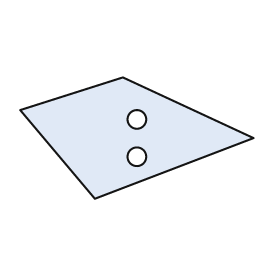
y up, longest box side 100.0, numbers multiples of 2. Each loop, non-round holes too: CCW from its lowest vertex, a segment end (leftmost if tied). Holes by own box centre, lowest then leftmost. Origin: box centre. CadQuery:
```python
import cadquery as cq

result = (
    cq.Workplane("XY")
    .moveTo(-18.0, -26.0)
    .lineTo(50.0, 0.0)
    .lineTo(-6.0, 26.0)
    .lineTo(-50.0, 12.0)
    .close()
    .moveTo(0.0, -8.0)
    .circle(4.0)
    .moveTo(0.0, 8.0)
    .circle(4.0)
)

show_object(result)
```